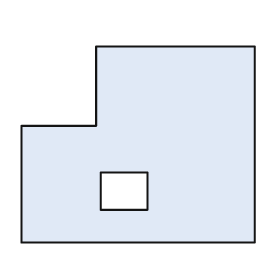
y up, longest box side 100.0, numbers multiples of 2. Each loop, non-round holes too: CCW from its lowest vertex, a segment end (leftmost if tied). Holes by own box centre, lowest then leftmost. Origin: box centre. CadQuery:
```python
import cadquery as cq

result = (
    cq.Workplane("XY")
    .moveTo(-50.0, -42.0)
    .lineTo(50.0, -42.0)
    .lineTo(50.0, 42.0)
    .lineTo(-18.0, 42.0)
    .lineTo(-18.0, 8.0)
    .lineTo(-50.0, 8.0)
    .close()
    .moveTo(-16.0, -28.0)
    .lineTo(4.0, -28.0)
    .lineTo(4.0, -12.0)
    .lineTo(-16.0, -12.0)
    .close()
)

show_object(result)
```